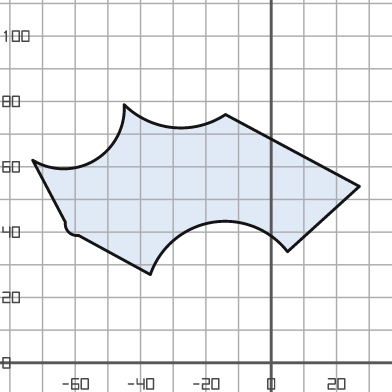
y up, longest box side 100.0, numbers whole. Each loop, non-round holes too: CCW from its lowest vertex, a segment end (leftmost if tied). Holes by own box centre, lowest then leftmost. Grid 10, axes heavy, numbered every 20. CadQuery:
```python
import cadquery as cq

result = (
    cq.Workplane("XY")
    .moveTo(-37.0, 27.0)
    .threePointArc((-18.0, 43.0), (5.0, 34.0))
    .lineTo(27.0, 54.0)
    .lineTo(-14.0, 76.0)
    .threePointArc((-30.0, 72.0), (-45.0, 79.0))
    .threePointArc((-54.0, 62.0), (-73.0, 62.0))
    .lineTo(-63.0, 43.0)
    .threePointArc((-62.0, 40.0), (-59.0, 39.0))
    .close()
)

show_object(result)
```